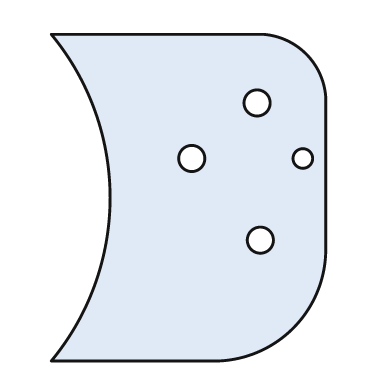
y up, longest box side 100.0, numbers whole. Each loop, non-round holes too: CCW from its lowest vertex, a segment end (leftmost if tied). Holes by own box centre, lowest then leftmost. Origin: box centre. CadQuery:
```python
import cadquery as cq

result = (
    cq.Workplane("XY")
    .moveTo(-42.0, -50.0)
    .lineTo(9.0, -50.0)
    .threePointArc((32.0, -40.0), (42.0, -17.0))
    .lineTo(42.0, 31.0)
    .threePointArc((36.0, 44.0), (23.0, 50.0))
    .lineTo(-42.0, 50.0)
    .threePointArc((-24.0, 0.0), (-42.0, -50.0))
    .close()
    .moveTo(22.0, -13.0)
    .circle(4.0)
    .moveTo(1.0, 12.0)
    .circle(4.0)
    .moveTo(35.0, 12.0)
    .circle(3.0)
    .moveTo(21.0, 29.0)
    .circle(4.0)
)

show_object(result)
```